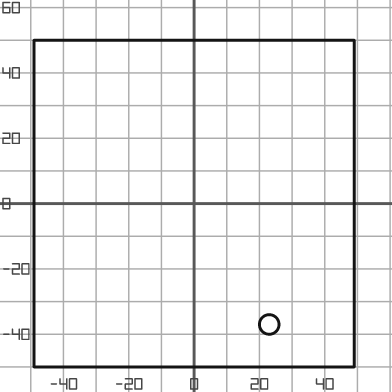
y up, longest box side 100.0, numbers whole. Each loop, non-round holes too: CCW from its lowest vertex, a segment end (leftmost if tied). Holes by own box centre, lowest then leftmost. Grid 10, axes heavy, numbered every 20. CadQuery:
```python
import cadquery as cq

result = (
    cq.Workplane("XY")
    .moveTo(-49.0, -50.0)
    .lineTo(49.0, -50.0)
    .lineTo(49.0, 50.0)
    .lineTo(-49.0, 50.0)
    .close()
    .moveTo(23.0, -37.0)
    .circle(3.0)
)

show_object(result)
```